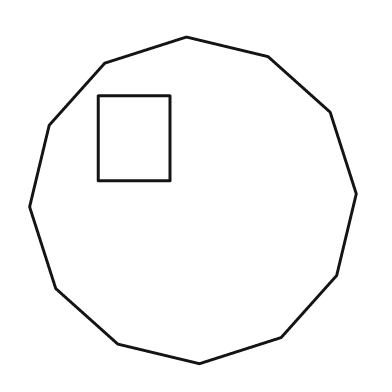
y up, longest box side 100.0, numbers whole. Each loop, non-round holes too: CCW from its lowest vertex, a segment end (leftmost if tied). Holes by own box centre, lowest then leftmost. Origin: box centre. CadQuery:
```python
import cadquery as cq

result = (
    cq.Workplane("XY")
    .moveTo(2.0, -50.0)
    .lineTo(27.0, -42.0)
    .lineTo(44.0, -23.0)
    .lineTo(50.0, 2.0)
    .lineTo(42.0, 27.0)
    .lineTo(23.0, 44.0)
    .lineTo(-2.0, 50.0)
    .lineTo(-27.0, 42.0)
    .lineTo(-44.0, 23.0)
    .lineTo(-50.0, -2.0)
    .lineTo(-42.0, -27.0)
    .lineTo(-23.0, -44.0)
    .close()
    .moveTo(-29.0, 6.0)
    .lineTo(-7.0, 6.0)
    .lineTo(-7.0, 32.0)
    .lineTo(-29.0, 32.0)
    .close()
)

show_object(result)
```